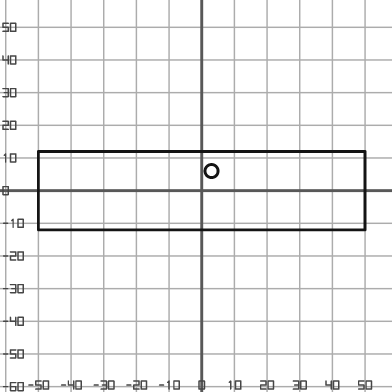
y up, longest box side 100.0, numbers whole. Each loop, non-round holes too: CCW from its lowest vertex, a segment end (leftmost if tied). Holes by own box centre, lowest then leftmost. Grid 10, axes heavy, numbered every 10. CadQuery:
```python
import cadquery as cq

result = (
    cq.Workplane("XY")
    .moveTo(-50.0, -12.0)
    .lineTo(50.0, -12.0)
    .lineTo(50.0, 12.0)
    .lineTo(-50.0, 12.0)
    .close()
    .moveTo(3.0, 6.0)
    .circle(2.0)
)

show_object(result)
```